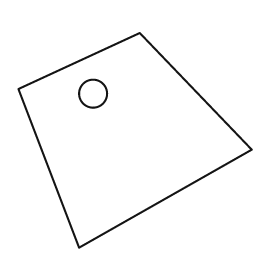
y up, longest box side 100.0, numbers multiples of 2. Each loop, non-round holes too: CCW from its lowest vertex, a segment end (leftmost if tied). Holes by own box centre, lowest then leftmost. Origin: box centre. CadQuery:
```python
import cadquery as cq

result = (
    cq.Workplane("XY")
    .moveTo(-24.0, -46.0)
    .lineTo(50.0, -4.0)
    .lineTo(2.0, 46.0)
    .lineTo(-50.0, 22.0)
    .close()
    .moveTo(-18.0, 20.0)
    .circle(6.0)
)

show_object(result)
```